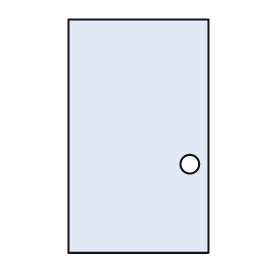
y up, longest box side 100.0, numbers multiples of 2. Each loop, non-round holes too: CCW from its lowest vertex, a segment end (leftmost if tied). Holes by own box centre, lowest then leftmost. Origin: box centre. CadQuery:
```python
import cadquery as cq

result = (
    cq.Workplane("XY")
    .moveTo(-30.0, -50.0)
    .lineTo(30.0, -50.0)
    .lineTo(30.0, 50.0)
    .lineTo(-30.0, 50.0)
    .close()
    .moveTo(22.0, -12.0)
    .circle(4.0)
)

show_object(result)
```